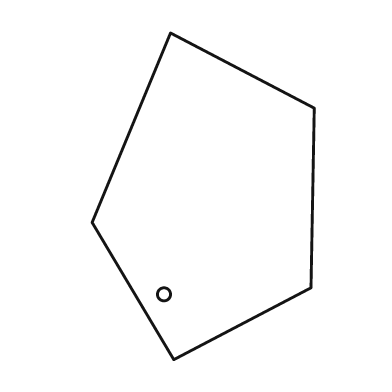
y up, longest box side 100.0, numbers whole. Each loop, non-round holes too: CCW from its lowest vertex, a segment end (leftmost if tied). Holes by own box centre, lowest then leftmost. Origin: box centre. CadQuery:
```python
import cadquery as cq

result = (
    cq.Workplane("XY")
    .moveTo(-9.0, -50.0)
    .lineTo(33.0, -28.0)
    .lineTo(34.0, 27.0)
    .lineTo(-10.0, 50.0)
    .lineTo(-34.0, -8.0)
    .close()
    .moveTo(-12.0, -30.0)
    .circle(2.0)
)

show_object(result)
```